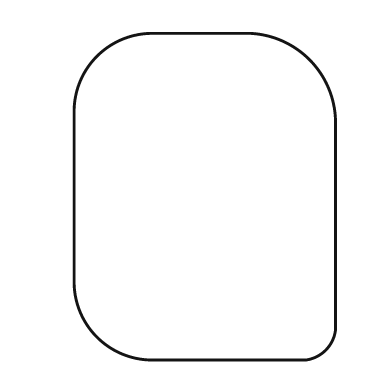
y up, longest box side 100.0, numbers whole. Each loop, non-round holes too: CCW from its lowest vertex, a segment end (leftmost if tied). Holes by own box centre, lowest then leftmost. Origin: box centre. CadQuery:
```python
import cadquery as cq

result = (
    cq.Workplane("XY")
    .moveTo(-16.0, -50.0)
    .lineTo(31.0, -50.0)
    .threePointArc((37.0, -47.0), (40.0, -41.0))
    .lineTo(40.0, 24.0)
    .threePointArc((32.0, 42.0), (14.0, 50.0))
    .lineTo(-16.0, 50.0)
    .threePointArc((-33.0, 43.0), (-40.0, 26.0))
    .lineTo(-40.0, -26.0)
    .threePointArc((-33.0, -43.0), (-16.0, -50.0))
    .close()
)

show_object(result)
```